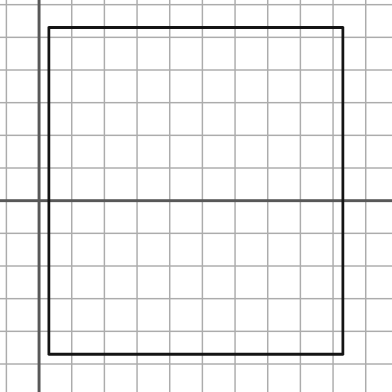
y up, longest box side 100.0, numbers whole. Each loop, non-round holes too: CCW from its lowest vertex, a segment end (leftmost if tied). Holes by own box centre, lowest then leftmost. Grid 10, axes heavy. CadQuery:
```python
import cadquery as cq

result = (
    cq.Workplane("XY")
    .moveTo(3.0, -47.0)
    .lineTo(93.0, -47.0)
    .lineTo(93.0, 53.0)
    .lineTo(3.0, 53.0)
    .close()
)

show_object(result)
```